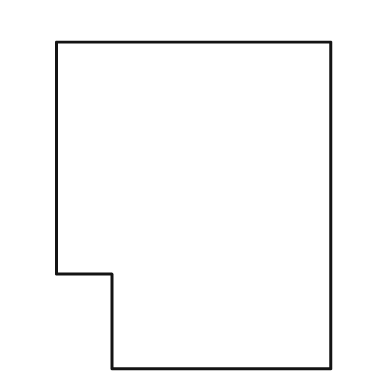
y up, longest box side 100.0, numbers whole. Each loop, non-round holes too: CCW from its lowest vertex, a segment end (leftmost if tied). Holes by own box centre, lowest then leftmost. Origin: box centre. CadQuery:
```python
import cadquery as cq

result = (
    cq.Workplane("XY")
    .moveTo(-25.0, -50.0)
    .lineTo(42.0, -50.0)
    .lineTo(42.0, 50.0)
    .lineTo(-42.0, 50.0)
    .lineTo(-42.0, -21.0)
    .lineTo(-25.0, -21.0)
    .close()
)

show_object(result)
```